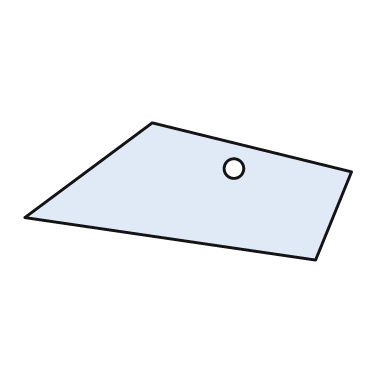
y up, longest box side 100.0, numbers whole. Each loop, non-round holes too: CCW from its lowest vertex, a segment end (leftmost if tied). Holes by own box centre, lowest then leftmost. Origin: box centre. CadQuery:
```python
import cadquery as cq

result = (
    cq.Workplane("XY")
    .moveTo(39.0, -21.0)
    .lineTo(50.0, 6.0)
    .lineTo(-11.0, 21.0)
    .lineTo(-50.0, -8.0)
    .close()
    .moveTo(14.0, 7.0)
    .circle(3.0)
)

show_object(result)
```